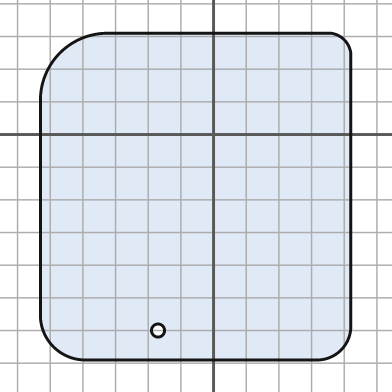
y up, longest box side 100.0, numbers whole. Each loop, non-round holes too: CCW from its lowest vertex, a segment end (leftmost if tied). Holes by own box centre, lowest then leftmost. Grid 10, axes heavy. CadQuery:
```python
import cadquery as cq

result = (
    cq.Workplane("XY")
    .moveTo(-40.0, -69.0)
    .lineTo(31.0, -69.0)
    .threePointArc((39.0, -66.0), (42.0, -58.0))
    .lineTo(42.0, 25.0)
    .threePointArc((40.0, 29.0), (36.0, 31.0))
    .lineTo(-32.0, 31.0)
    .threePointArc((-47.0, 25.0), (-53.0, 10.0))
    .lineTo(-53.0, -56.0)
    .threePointArc((-49.0, -65.0), (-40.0, -69.0))
    .close()
    .moveTo(-17.0, -60.0)
    .circle(2.0)
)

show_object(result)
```